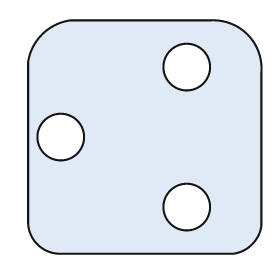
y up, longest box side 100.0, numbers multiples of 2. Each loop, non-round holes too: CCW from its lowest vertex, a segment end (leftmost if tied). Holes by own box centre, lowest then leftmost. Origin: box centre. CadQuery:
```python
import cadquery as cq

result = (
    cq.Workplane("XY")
    .moveTo(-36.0, -50.0)
    .lineTo(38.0, -50.0)
    .threePointArc((46.0, -46.0), (50.0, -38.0))
    .lineTo(50.0, 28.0)
    .threePointArc((44.0, 44.0), (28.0, 50.0))
    .lineTo(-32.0, 50.0)
    .threePointArc((-44.0, 44.0), (-50.0, 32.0))
    .lineTo(-50.0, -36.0)
    .threePointArc((-46.0, -46.0), (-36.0, -50.0))
    .close()
    .moveTo(18.0, -30.0)
    .circle(10.0)
    .moveTo(-36.0, 0.0)
    .circle(10.0)
    .moveTo(18.0, 30.0)
    .circle(10.0)
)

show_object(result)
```